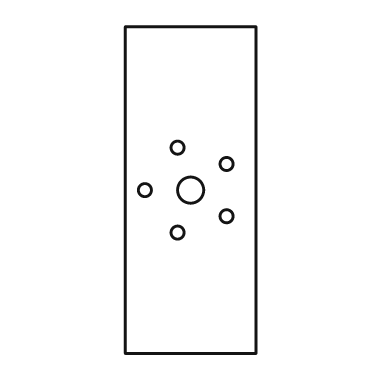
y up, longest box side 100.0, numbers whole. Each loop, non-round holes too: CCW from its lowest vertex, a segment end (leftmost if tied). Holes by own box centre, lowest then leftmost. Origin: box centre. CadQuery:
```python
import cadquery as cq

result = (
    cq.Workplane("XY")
    .moveTo(-20.0, -50.0)
    .lineTo(20.0, -50.0)
    .lineTo(20.0, 50.0)
    .lineTo(-20.0, 50.0)
    .close()
    .moveTo(-4.0, -13.0)
    .circle(2.0)
    .moveTo(11.0, -8.0)
    .circle(2.0)
    .moveTo(-14.0, 0.0)
    .circle(2.0)
    .moveTo(0.0, 0.0)
    .circle(4.0)
    .moveTo(11.0, 8.0)
    .circle(2.0)
    .moveTo(-4.0, 13.0)
    .circle(2.0)
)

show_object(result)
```